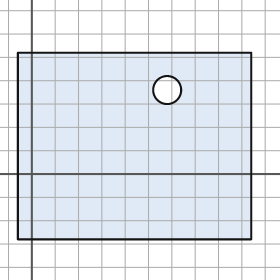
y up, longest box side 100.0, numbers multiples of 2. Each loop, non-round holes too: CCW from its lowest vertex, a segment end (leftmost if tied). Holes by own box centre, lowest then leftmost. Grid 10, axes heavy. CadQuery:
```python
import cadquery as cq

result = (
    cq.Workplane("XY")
    .moveTo(-6.0, -28.0)
    .lineTo(94.0, -28.0)
    .lineTo(94.0, 52.0)
    .lineTo(-6.0, 52.0)
    .close()
    .moveTo(58.0, 36.0)
    .circle(6.0)
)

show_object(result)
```